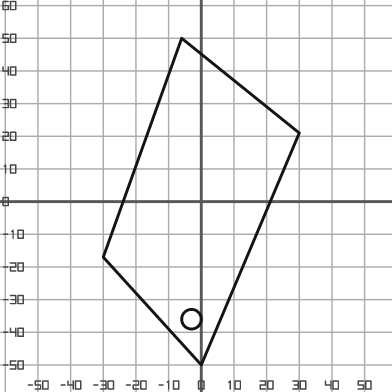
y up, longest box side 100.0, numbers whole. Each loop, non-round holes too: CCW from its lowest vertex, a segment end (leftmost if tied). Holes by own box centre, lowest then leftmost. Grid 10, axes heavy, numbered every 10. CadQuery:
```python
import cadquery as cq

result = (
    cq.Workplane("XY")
    .moveTo(0.0, -50.0)
    .lineTo(30.0, 21.0)
    .lineTo(-6.0, 50.0)
    .lineTo(-30.0, -17.0)
    .close()
    .moveTo(-3.0, -36.0)
    .circle(3.0)
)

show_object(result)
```